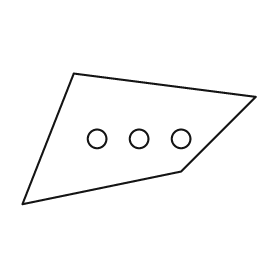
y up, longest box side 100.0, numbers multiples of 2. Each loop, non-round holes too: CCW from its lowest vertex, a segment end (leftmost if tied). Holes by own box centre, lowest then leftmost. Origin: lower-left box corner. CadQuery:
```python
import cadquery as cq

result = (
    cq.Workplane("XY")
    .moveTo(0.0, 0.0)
    .lineTo(68.0, 14.0)
    .lineTo(100.0, 46.0)
    .lineTo(22.0, 56.0)
    .close()
    .moveTo(32.0, 28.0)
    .circle(4.0)
    .moveTo(50.0, 28.0)
    .circle(4.0)
    .moveTo(68.0, 28.0)
    .circle(4.0)
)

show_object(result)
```